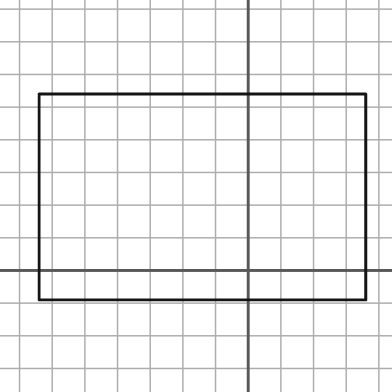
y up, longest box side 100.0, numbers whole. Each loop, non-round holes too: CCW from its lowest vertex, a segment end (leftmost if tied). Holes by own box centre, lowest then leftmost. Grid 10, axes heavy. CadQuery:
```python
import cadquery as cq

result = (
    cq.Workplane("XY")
    .moveTo(-64.0, -9.0)
    .lineTo(36.0, -9.0)
    .lineTo(36.0, 54.0)
    .lineTo(-64.0, 54.0)
    .close()
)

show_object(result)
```